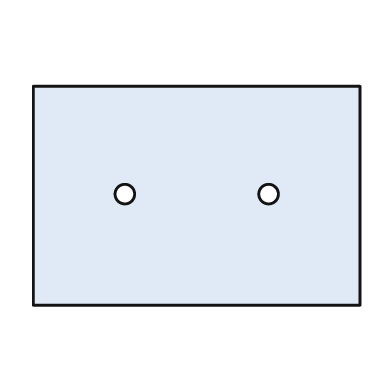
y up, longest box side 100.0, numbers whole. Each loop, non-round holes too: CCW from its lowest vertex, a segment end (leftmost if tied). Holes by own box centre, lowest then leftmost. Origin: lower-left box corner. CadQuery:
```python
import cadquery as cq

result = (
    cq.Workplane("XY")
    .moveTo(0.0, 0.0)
    .lineTo(100.0, 0.0)
    .lineTo(100.0, 67.0)
    .lineTo(0.0, 67.0)
    .close()
    .moveTo(28.0, 34.0)
    .circle(3.0)
    .moveTo(72.0, 34.0)
    .circle(3.0)
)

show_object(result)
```